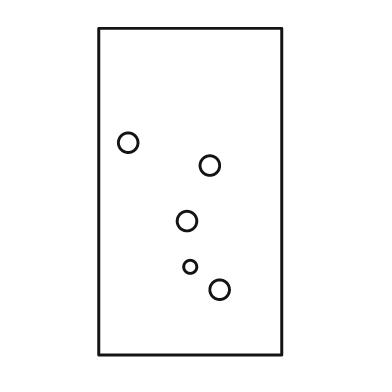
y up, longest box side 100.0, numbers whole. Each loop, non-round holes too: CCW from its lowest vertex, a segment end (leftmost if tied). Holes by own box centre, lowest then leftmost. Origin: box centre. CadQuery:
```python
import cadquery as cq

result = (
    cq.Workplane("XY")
    .moveTo(-28.0, -50.0)
    .lineTo(28.0, -50.0)
    .lineTo(28.0, 50.0)
    .lineTo(-28.0, 50.0)
    .close()
    .moveTo(9.0, -30.0)
    .circle(3.0)
    .moveTo(0.0, -23.0)
    .circle(2.0)
    .moveTo(-1.0, -9.0)
    .circle(3.0)
    .moveTo(6.0, 8.0)
    .circle(3.0)
    .moveTo(-19.0, 15.0)
    .circle(3.0)
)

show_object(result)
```